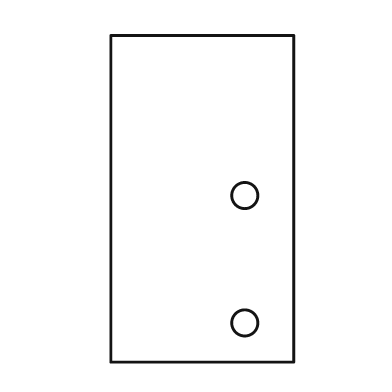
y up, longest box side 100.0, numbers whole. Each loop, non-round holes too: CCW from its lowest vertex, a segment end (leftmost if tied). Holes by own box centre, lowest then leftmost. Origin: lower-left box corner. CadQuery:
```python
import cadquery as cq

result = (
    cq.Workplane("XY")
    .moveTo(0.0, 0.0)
    .lineTo(56.0, 0.0)
    .lineTo(56.0, 100.0)
    .lineTo(0.0, 100.0)
    .close()
    .moveTo(41.0, 12.0)
    .circle(4.0)
    .moveTo(41.0, 51.0)
    .circle(4.0)
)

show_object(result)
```